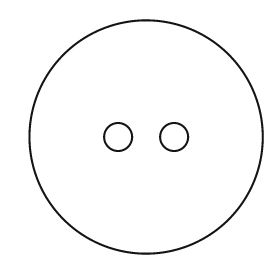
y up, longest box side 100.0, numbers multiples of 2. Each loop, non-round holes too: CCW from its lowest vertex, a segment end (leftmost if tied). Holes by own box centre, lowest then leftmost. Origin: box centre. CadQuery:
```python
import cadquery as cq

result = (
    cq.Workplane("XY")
    .moveTo(0.0, 0.0)
    .circle(50.0)
    .moveTo(-12.0, 0.0)
    .circle(6.0)
    .moveTo(12.0, 0.0)
    .circle(6.0)
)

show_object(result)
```